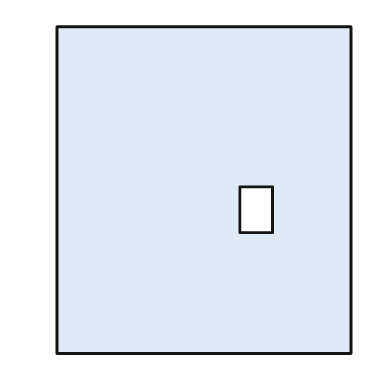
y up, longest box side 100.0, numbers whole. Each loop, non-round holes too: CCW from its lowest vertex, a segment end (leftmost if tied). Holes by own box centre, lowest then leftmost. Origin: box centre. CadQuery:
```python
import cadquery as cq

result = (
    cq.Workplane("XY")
    .moveTo(-45.0, -50.0)
    .lineTo(45.0, -50.0)
    .lineTo(45.0, 50.0)
    .lineTo(-45.0, 50.0)
    .close()
    .moveTo(11.0, -13.0)
    .lineTo(21.0, -13.0)
    .lineTo(21.0, 1.0)
    .lineTo(11.0, 1.0)
    .close()
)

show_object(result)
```